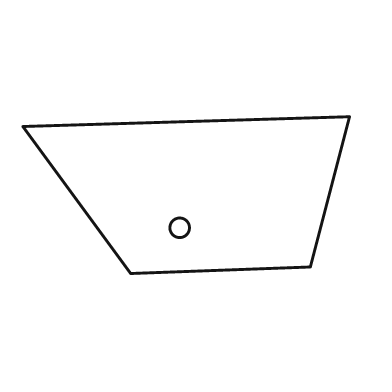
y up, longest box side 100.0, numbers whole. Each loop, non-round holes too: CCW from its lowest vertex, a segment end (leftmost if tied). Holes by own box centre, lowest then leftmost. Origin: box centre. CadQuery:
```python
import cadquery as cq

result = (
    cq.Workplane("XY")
    .moveTo(-17.0, -24.0)
    .lineTo(38.0, -22.0)
    .lineTo(50.0, 24.0)
    .lineTo(-50.0, 21.0)
    .close()
    .moveTo(-2.0, -10.0)
    .circle(3.0)
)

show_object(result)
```